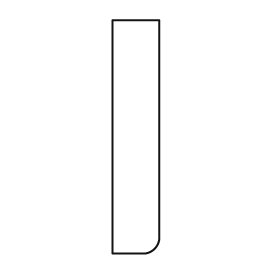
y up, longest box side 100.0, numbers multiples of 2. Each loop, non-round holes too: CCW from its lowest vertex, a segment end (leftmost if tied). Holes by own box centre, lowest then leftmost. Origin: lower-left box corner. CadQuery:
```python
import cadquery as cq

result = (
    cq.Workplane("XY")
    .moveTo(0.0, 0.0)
    .lineTo(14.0, 0.0)
    .threePointArc((18.0, 2.0), (20.0, 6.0))
    .lineTo(20.0, 100.0)
    .lineTo(0.0, 100.0)
    .close()
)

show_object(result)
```